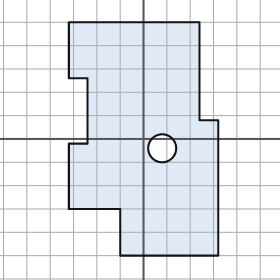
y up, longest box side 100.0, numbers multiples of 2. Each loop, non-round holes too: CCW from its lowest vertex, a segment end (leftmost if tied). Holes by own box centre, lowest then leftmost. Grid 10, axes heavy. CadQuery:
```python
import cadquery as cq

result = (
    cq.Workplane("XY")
    .moveTo(-10.0, -50.0)
    .lineTo(32.0, -50.0)
    .lineTo(32.0, 8.0)
    .lineTo(24.0, 8.0)
    .lineTo(24.0, 50.0)
    .lineTo(-32.0, 50.0)
    .lineTo(-32.0, 26.0)
    .lineTo(-24.0, 26.0)
    .lineTo(-24.0, -2.0)
    .lineTo(-32.0, -2.0)
    .lineTo(-32.0, -30.0)
    .lineTo(-10.0, -30.0)
    .close()
    .moveTo(8.0, -4.0)
    .circle(6.0)
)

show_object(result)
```